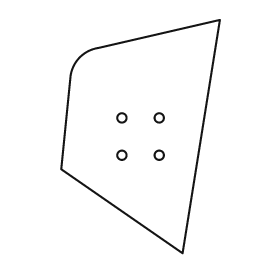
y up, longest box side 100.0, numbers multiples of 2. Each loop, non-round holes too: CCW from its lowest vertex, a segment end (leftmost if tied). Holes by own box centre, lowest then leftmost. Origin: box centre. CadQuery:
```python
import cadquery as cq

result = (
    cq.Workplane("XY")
    .moveTo(18.0, -50.0)
    .lineTo(34.0, 50.0)
    .lineTo(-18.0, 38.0)
    .threePointArc((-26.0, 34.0), (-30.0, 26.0))
    .lineTo(-34.0, -14.0)
    .close()
    .moveTo(-8.0, -8.0)
    .circle(2.0)
    .moveTo(8.0, -8.0)
    .circle(2.0)
    .moveTo(-8.0, 8.0)
    .circle(2.0)
    .moveTo(8.0, 8.0)
    .circle(2.0)
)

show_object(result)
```